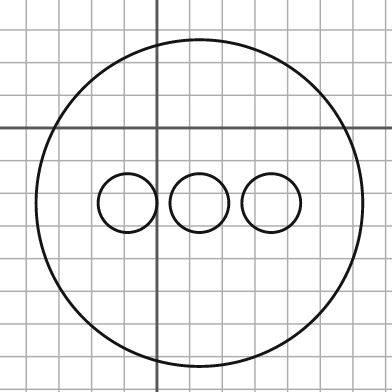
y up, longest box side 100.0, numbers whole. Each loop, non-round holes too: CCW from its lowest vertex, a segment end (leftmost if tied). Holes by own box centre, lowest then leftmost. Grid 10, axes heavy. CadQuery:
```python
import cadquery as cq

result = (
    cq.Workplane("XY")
    .moveTo(13.0, -23.0)
    .circle(50.0)
    .moveTo(-9.0, -23.0)
    .circle(9.0)
    .moveTo(13.0, -23.0)
    .circle(9.0)
    .moveTo(35.0, -23.0)
    .circle(9.0)
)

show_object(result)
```